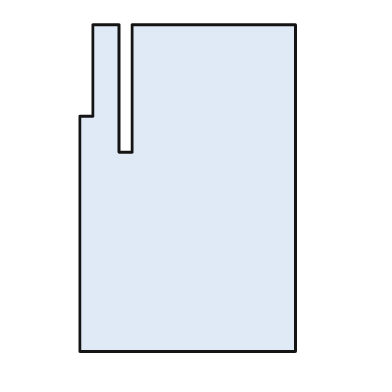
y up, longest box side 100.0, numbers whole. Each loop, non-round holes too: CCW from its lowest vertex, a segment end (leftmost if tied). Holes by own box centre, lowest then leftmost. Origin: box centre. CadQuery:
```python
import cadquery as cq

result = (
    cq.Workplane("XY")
    .moveTo(-33.0, -50.0)
    .lineTo(33.0, -50.0)
    .lineTo(33.0, 50.0)
    .lineTo(-17.0, 50.0)
    .lineTo(-17.0, 11.0)
    .lineTo(-21.0, 11.0)
    .lineTo(-21.0, 50.0)
    .lineTo(-29.0, 50.0)
    .lineTo(-29.0, 22.0)
    .lineTo(-33.0, 22.0)
    .close()
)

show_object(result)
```